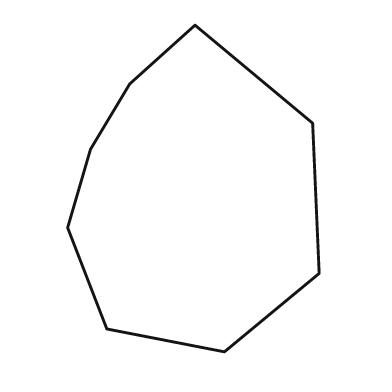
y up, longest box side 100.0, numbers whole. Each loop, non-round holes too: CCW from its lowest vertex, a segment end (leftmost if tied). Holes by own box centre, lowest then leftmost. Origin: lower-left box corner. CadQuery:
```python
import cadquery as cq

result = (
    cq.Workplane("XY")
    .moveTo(48.0, 0.0)
    .lineTo(77.0, 24.0)
    .lineTo(75.0, 70.0)
    .lineTo(39.0, 100.0)
    .lineTo(19.0, 82.0)
    .lineTo(7.0, 62.0)
    .lineTo(0.0, 38.0)
    .lineTo(12.0, 7.0)
    .close()
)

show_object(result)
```